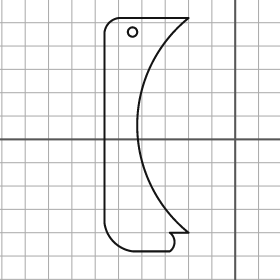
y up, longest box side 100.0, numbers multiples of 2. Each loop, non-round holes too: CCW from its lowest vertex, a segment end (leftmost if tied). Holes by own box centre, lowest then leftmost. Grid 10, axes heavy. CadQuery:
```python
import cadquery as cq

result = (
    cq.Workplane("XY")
    .moveTo(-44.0, -48.0)
    .lineTo(-28.0, -48.0)
    .threePointArc((-26.0, -44.0), (-28.0, -40.0))
    .lineTo(-20.0, -40.0)
    .threePointArc((-42.0, 6.0), (-20.0, 52.0))
    .lineTo(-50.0, 52.0)
    .threePointArc((-54.0, 50.0), (-56.0, 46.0))
    .lineTo(-56.0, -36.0)
    .threePointArc((-52.0, -44.0), (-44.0, -48.0))
    .close()
    .moveTo(-44.0, 46.0)
    .circle(2.0)
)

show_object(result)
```